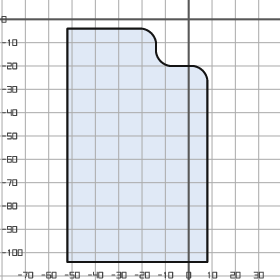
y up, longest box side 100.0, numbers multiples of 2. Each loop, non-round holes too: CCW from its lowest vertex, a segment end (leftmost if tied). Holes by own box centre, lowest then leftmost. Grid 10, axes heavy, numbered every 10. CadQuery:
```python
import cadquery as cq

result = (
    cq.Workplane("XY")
    .moveTo(-52.0, -104.0)
    .lineTo(8.0, -104.0)
    .lineTo(8.0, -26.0)
    .threePointArc((6.0, -22.0), (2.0, -20.0))
    .lineTo(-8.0, -20.0)
    .threePointArc((-12.0, -18.0), (-14.0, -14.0))
    .lineTo(-14.0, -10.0)
    .threePointArc((-16.0, -6.0), (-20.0, -4.0))
    .lineTo(-52.0, -4.0)
    .close()
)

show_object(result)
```